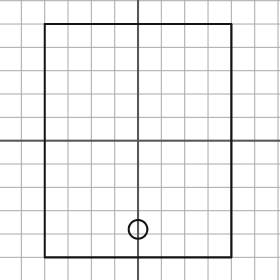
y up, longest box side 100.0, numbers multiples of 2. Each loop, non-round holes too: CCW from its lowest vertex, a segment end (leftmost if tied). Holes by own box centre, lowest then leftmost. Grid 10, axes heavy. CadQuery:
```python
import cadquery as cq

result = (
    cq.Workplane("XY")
    .moveTo(-40.0, -50.0)
    .lineTo(40.0, -50.0)
    .lineTo(40.0, 50.0)
    .lineTo(-40.0, 50.0)
    .close()
    .moveTo(0.0, -38.0)
    .circle(4.0)
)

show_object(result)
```